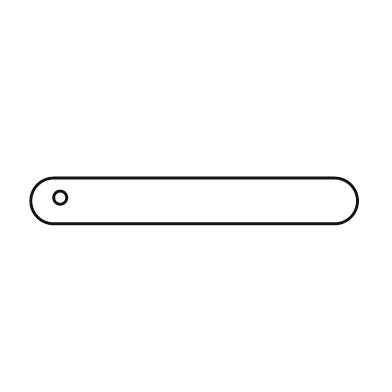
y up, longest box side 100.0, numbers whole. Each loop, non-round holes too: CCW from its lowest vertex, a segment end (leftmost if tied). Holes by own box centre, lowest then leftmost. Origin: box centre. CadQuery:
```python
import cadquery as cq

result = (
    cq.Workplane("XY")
    .moveTo(-43.0, -7.0)
    .lineTo(43.0, -7.0)
    .threePointArc((50.0, 0.0), (43.0, 7.0))
    .lineTo(-43.0, 7.0)
    .threePointArc((-50.0, 0.0), (-43.0, -7.0))
    .close()
    .moveTo(-41.0, 1.0)
    .circle(2.0)
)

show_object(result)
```